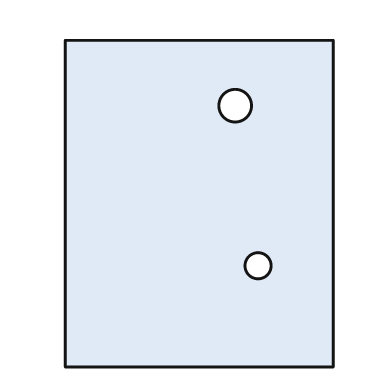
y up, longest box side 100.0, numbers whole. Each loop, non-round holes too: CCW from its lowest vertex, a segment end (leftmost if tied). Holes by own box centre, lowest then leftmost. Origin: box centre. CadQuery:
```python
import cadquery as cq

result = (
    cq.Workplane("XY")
    .moveTo(-41.0, -50.0)
    .lineTo(41.0, -50.0)
    .lineTo(41.0, 50.0)
    .lineTo(-41.0, 50.0)
    .close()
    .moveTo(18.0, -19.0)
    .circle(4.0)
    .moveTo(11.0, 30.0)
    .circle(5.0)
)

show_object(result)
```